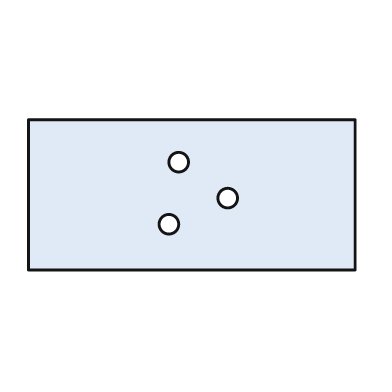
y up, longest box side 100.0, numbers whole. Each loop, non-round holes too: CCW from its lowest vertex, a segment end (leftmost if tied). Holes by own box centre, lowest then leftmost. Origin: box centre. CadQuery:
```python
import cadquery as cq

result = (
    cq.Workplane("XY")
    .moveTo(-50.0, -23.0)
    .lineTo(50.0, -23.0)
    .lineTo(50.0, 23.0)
    .lineTo(-50.0, 23.0)
    .close()
    .moveTo(-7.0, -9.0)
    .circle(3.0)
    .moveTo(11.0, -1.0)
    .circle(3.0)
    .moveTo(-4.0, 10.0)
    .circle(3.0)
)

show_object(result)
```